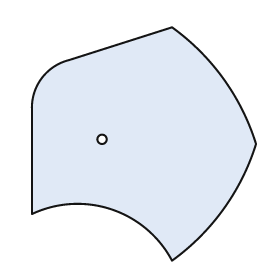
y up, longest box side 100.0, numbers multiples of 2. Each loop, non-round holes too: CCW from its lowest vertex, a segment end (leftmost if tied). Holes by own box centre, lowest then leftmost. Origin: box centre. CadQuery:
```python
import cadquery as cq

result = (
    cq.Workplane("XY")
    .moveTo(12.0, -50.0)
    .threePointArc((34.0, -28.0), (48.0, 0.0))
    .threePointArc((34.0, 28.0), (12.0, 50.0))
    .lineTo(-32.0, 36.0)
    .threePointArc((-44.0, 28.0), (-48.0, 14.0))
    .lineTo(-48.0, -30.0)
    .threePointArc((-14.0, -28.0), (12.0, -50.0))
    .close()
    .moveTo(-18.0, 2.0)
    .circle(2.0)
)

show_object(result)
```